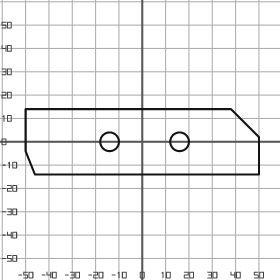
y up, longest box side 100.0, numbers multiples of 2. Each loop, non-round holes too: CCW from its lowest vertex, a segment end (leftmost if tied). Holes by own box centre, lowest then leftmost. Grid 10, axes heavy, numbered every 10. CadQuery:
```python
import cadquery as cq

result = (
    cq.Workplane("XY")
    .moveTo(-46.0, -14.0)
    .lineTo(50.0, -14.0)
    .lineTo(50.0, 2.0)
    .lineTo(38.0, 14.0)
    .lineTo(-50.0, 14.0)
    .lineTo(-50.0, -4.0)
    .close()
    .moveTo(-14.0, 0.0)
    .circle(4.0)
    .moveTo(16.0, 0.0)
    .circle(4.0)
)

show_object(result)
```